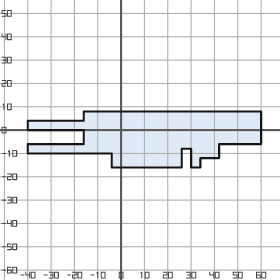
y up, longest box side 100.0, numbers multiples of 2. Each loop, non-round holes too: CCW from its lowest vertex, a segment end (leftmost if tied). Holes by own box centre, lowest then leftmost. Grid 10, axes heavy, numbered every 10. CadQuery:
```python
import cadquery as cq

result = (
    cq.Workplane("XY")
    .moveTo(-4.0, -16.0)
    .lineTo(26.0, -16.0)
    .lineTo(26.0, -8.0)
    .lineTo(30.0, -8.0)
    .lineTo(30.0, -16.0)
    .lineTo(34.0, -16.0)
    .lineTo(34.0, -12.0)
    .lineTo(42.0, -12.0)
    .lineTo(42.0, -6.0)
    .lineTo(60.0, -6.0)
    .lineTo(60.0, 8.0)
    .lineTo(-16.0, 8.0)
    .lineTo(-16.0, 4.0)
    .lineTo(-40.0, 4.0)
    .lineTo(-40.0, 0.0)
    .lineTo(-16.0, 0.0)
    .lineTo(-16.0, -6.0)
    .lineTo(-40.0, -6.0)
    .lineTo(-40.0, -10.0)
    .lineTo(-4.0, -10.0)
    .close()
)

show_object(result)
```